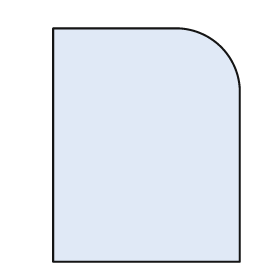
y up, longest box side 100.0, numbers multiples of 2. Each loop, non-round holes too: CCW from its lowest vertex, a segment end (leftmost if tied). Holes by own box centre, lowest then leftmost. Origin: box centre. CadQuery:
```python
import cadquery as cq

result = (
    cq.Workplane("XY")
    .moveTo(-40.0, -50.0)
    .lineTo(40.0, -50.0)
    .lineTo(40.0, 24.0)
    .threePointArc((32.0, 42.0), (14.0, 50.0))
    .lineTo(-40.0, 50.0)
    .close()
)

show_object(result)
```